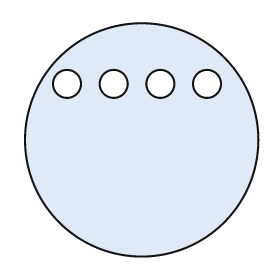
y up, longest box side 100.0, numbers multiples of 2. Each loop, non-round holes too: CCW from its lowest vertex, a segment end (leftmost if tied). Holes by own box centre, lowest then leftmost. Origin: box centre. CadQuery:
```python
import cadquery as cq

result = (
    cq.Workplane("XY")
    .moveTo(0.0, 0.0)
    .circle(50.0)
    .moveTo(-32.0, 24.0)
    .circle(6.0)
    .moveTo(-12.0, 24.0)
    .circle(6.0)
    .moveTo(8.0, 24.0)
    .circle(6.0)
    .moveTo(28.0, 24.0)
    .circle(6.0)
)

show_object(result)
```